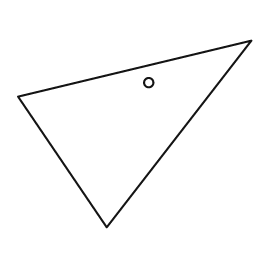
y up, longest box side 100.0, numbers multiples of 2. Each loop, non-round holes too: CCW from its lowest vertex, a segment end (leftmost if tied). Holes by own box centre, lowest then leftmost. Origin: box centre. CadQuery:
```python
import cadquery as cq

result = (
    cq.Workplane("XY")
    .moveTo(-12.0, -40.0)
    .lineTo(50.0, 40.0)
    .lineTo(-50.0, 16.0)
    .close()
    .moveTo(6.0, 22.0)
    .circle(2.0)
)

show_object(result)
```